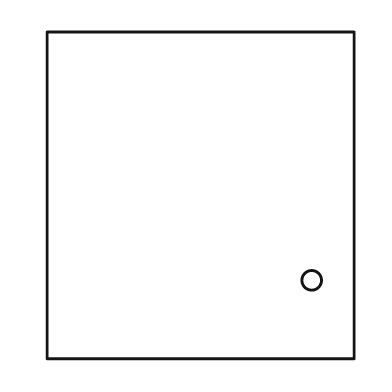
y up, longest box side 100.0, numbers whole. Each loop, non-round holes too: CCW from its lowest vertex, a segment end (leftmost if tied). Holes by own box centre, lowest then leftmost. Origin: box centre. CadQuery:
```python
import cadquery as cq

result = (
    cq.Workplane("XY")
    .moveTo(-47.0, -50.0)
    .lineTo(47.0, -50.0)
    .lineTo(47.0, 50.0)
    .lineTo(-47.0, 50.0)
    .close()
    .moveTo(34.0, -26.0)
    .circle(3.0)
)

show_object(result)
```